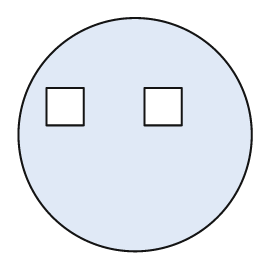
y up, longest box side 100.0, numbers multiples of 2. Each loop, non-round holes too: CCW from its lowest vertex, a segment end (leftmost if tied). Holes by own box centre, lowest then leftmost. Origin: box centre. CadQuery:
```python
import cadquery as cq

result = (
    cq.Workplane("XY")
    .moveTo(0.0, 0.0)
    .circle(50.0)
    .moveTo(-38.0, 4.0)
    .lineTo(-22.0, 4.0)
    .lineTo(-22.0, 20.0)
    .lineTo(-38.0, 20.0)
    .close()
    .moveTo(4.0, 4.0)
    .lineTo(20.0, 4.0)
    .lineTo(20.0, 20.0)
    .lineTo(4.0, 20.0)
    .close()
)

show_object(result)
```